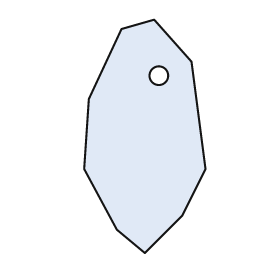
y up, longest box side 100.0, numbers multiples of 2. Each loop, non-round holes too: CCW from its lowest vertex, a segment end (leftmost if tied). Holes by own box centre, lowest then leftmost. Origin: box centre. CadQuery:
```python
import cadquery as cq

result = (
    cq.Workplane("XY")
    .moveTo(0.0, -50.0)
    .lineTo(16.0, -34.0)
    .lineTo(26.0, -14.0)
    .lineTo(20.0, 32.0)
    .lineTo(4.0, 50.0)
    .lineTo(-10.0, 46.0)
    .lineTo(-24.0, 16.0)
    .lineTo(-26.0, -14.0)
    .lineTo(-12.0, -40.0)
    .close()
    .moveTo(6.0, 26.0)
    .circle(4.0)
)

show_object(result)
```